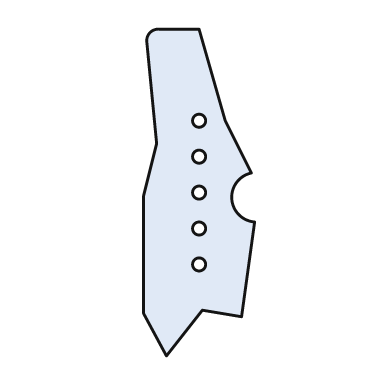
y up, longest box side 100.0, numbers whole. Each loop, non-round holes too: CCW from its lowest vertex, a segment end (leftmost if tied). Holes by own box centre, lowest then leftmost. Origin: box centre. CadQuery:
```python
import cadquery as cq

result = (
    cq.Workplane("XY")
    .moveTo(-10.0, -50.0)
    .lineTo(1.0, -36.0)
    .lineTo(13.0, -38.0)
    .lineTo(17.0, -9.0)
    .threePointArc((10.0, -2.0), (16.0, 6.0))
    .lineTo(8.0, 22.0)
    .lineTo(0.0, 50.0)
    .lineTo(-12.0, 50.0)
    .threePointArc((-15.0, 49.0), (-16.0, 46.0))
    .lineTo(-13.0, 15.0)
    .lineTo(-17.0, -1.0)
    .lineTo(-17.0, -37.0)
    .close()
    .moveTo(0.0, -22.0)
    .circle(2.0)
    .moveTo(0.0, -11.0)
    .circle(2.0)
    .moveTo(0.0, 0.0)
    .circle(2.0)
    .moveTo(0.0, 11.0)
    .circle(2.0)
    .moveTo(0.0, 22.0)
    .circle(2.0)
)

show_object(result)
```